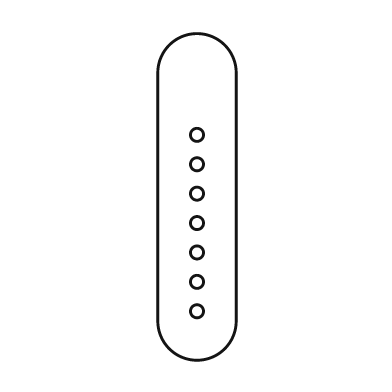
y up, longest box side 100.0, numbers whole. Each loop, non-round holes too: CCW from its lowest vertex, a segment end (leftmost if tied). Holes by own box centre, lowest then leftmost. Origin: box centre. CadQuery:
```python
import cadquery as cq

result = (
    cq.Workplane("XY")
    .moveTo(-12.0, -38.0)
    .threePointArc((0.0, -50.0), (12.0, -38.0))
    .lineTo(12.0, 38.0)
    .threePointArc((0.0, 50.0), (-12.0, 38.0))
    .close()
    .moveTo(0.0, -35.0)
    .circle(2.0)
    .moveTo(0.0, -26.0)
    .circle(2.0)
    .moveTo(0.0, -17.0)
    .circle(2.0)
    .moveTo(0.0, -8.0)
    .circle(2.0)
    .moveTo(0.0, 1.0)
    .circle(2.0)
    .moveTo(0.0, 10.0)
    .circle(2.0)
    .moveTo(0.0, 19.0)
    .circle(2.0)
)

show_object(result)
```